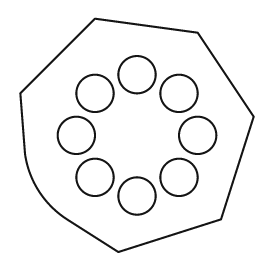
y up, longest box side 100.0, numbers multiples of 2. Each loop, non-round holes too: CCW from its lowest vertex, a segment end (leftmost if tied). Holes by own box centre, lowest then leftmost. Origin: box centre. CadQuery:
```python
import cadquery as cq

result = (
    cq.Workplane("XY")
    .moveTo(-8.0, -50.0)
    .lineTo(36.0, -36.0)
    .lineTo(50.0, 8.0)
    .lineTo(26.0, 44.0)
    .lineTo(-18.0, 50.0)
    .lineTo(-50.0, 18.0)
    .lineTo(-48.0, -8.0)
    .threePointArc((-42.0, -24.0), (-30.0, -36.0))
    .close()
    .moveTo(0.0, -26.0)
    .circle(8.0)
    .moveTo(-18.0, -18.0)
    .circle(8.0)
    .moveTo(18.0, -18.0)
    .circle(8.0)
    .moveTo(-26.0, 0.0)
    .circle(8.0)
    .moveTo(26.0, 0.0)
    .circle(8.0)
    .moveTo(-18.0, 18.0)
    .circle(8.0)
    .moveTo(18.0, 18.0)
    .circle(8.0)
    .moveTo(0.0, 26.0)
    .circle(8.0)
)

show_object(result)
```